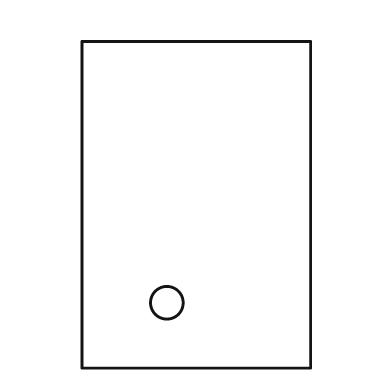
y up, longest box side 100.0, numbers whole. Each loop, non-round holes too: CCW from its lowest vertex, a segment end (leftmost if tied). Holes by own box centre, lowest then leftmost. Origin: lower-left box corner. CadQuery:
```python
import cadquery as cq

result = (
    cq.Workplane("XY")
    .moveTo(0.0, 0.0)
    .lineTo(70.0, 0.0)
    .lineTo(70.0, 100.0)
    .lineTo(0.0, 100.0)
    .close()
    .moveTo(26.0, 20.0)
    .circle(5.0)
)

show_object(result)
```